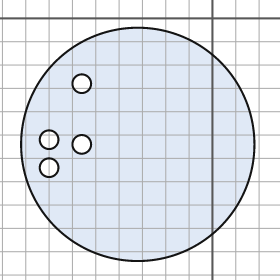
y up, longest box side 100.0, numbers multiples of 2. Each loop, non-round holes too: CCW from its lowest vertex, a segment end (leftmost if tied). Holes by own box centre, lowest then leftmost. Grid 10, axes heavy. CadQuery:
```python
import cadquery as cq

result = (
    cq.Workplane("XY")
    .moveTo(-32.0, -54.0)
    .circle(50.0)
    .moveTo(-70.0, -64.0)
    .circle(4.0)
    .moveTo(-56.0, -54.0)
    .circle(4.0)
    .moveTo(-70.0, -52.0)
    .circle(4.0)
    .moveTo(-56.0, -28.0)
    .circle(4.0)
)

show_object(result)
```